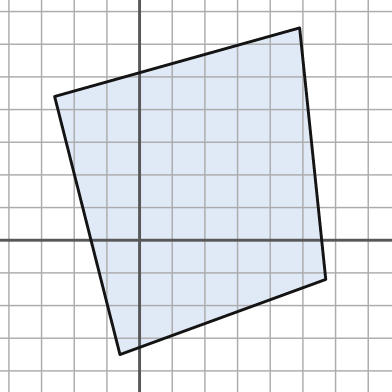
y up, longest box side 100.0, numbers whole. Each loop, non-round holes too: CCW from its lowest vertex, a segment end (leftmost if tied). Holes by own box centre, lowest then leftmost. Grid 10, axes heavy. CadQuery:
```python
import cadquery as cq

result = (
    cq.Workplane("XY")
    .moveTo(-6.0, -35.0)
    .lineTo(57.0, -12.0)
    .lineTo(49.0, 65.0)
    .lineTo(-26.0, 44.0)
    .close()
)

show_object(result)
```